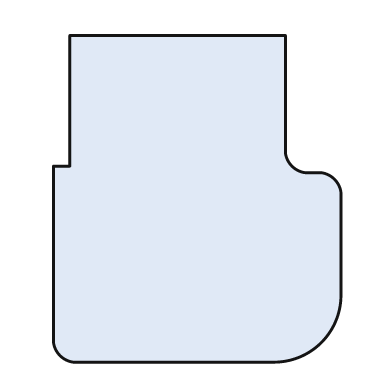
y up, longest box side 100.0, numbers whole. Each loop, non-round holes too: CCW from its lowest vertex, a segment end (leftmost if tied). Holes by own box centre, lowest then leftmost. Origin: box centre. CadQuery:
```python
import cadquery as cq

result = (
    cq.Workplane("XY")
    .moveTo(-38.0, -50.0)
    .lineTo(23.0, -50.0)
    .threePointArc((38.0, -44.0), (44.0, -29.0))
    .lineTo(44.0, 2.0)
    .threePointArc((42.0, 6.0), (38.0, 8.0))
    .lineTo(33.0, 8.0)
    .threePointArc((29.0, 10.0), (27.0, 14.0))
    .lineTo(27.0, 50.0)
    .lineTo(-39.0, 50.0)
    .lineTo(-39.0, 10.0)
    .lineTo(-44.0, 10.0)
    .lineTo(-44.0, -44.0)
    .threePointArc((-42.0, -48.0), (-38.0, -50.0))
    .close()
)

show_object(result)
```